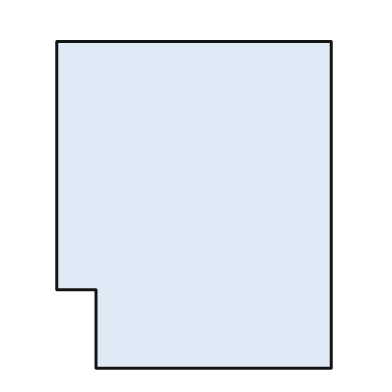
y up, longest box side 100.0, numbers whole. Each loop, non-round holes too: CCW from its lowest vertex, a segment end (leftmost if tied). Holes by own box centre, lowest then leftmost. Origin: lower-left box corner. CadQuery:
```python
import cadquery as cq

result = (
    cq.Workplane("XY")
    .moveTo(12.0, 0.0)
    .lineTo(84.0, 0.0)
    .lineTo(84.0, 100.0)
    .lineTo(0.0, 100.0)
    .lineTo(0.0, 24.0)
    .lineTo(12.0, 24.0)
    .close()
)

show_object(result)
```